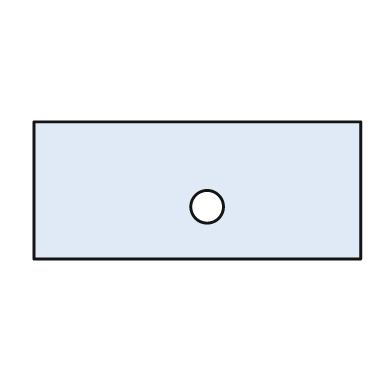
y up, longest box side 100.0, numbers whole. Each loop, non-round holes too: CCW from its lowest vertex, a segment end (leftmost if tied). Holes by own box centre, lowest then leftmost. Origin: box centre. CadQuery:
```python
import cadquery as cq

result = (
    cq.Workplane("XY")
    .moveTo(-50.0, -21.0)
    .lineTo(50.0, -21.0)
    .lineTo(50.0, 21.0)
    .lineTo(-50.0, 21.0)
    .close()
    .moveTo(3.0, -5.0)
    .circle(5.0)
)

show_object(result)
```